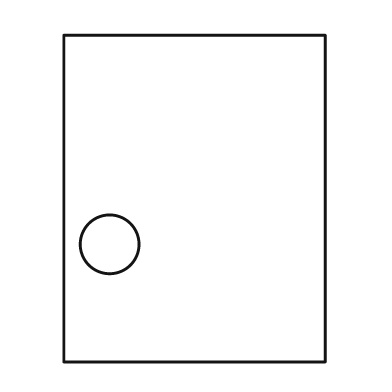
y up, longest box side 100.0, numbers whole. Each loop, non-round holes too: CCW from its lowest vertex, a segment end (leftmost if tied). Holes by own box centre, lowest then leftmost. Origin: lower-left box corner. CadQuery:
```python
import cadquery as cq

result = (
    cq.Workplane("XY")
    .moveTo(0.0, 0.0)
    .lineTo(80.0, 0.0)
    .lineTo(80.0, 100.0)
    .lineTo(0.0, 100.0)
    .close()
    .moveTo(14.0, 36.0)
    .circle(9.0)
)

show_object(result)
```